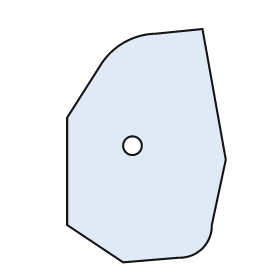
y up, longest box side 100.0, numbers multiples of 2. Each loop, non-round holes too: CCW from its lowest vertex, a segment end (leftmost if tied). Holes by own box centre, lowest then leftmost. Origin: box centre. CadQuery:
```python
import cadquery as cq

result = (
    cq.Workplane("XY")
    .moveTo(-10.0, -50.0)
    .lineTo(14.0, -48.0)
    .threePointArc((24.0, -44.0), (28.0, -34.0))
    .lineTo(34.0, -6.0)
    .lineTo(24.0, 50.0)
    .lineTo(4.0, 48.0)
    .threePointArc((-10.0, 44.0), (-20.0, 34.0))
    .lineTo(-34.0, 12.0)
    .lineTo(-34.0, -34.0)
    .close()
    .moveTo(-6.0, 0.0)
    .circle(4.0)
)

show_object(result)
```